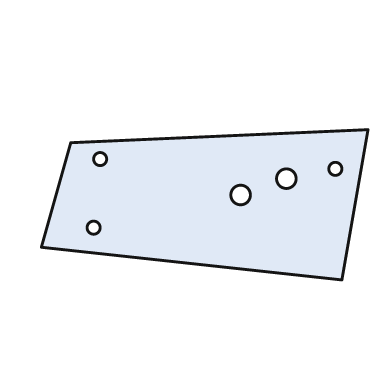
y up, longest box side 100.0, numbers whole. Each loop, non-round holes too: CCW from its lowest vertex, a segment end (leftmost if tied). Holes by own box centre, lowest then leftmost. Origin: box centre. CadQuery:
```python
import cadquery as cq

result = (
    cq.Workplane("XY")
    .moveTo(42.0, -23.0)
    .lineTo(50.0, 23.0)
    .lineTo(-41.0, 19.0)
    .lineTo(-50.0, -13.0)
    .close()
    .moveTo(-34.0, -7.0)
    .circle(2.0)
    .moveTo(11.0, 3.0)
    .circle(3.0)
    .moveTo(25.0, 8.0)
    .circle(3.0)
    .moveTo(40.0, 11.0)
    .circle(2.0)
    .moveTo(-32.0, 14.0)
    .circle(2.0)
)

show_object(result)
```